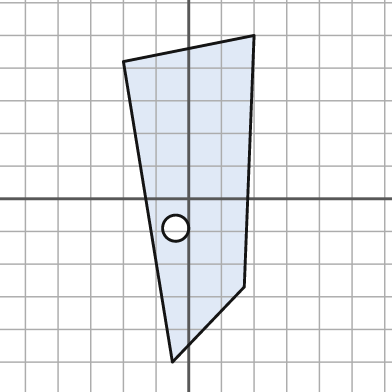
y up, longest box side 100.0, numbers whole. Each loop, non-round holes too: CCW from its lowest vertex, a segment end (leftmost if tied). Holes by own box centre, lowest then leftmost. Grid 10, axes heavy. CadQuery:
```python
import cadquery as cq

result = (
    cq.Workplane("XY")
    .moveTo(-5.0, -50.0)
    .lineTo(17.0, -27.0)
    .lineTo(20.0, 50.0)
    .lineTo(-20.0, 42.0)
    .close()
    .moveTo(-4.0, -9.0)
    .circle(4.0)
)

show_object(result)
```